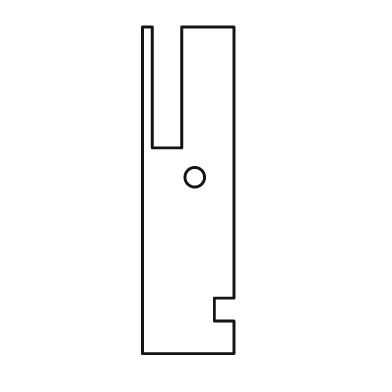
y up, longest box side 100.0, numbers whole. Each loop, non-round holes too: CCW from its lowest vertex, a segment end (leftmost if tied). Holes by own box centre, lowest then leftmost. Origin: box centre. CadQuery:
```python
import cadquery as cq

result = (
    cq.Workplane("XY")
    .moveTo(-14.0, -50.0)
    .lineTo(14.0, -50.0)
    .lineTo(14.0, -40.0)
    .lineTo(8.0, -40.0)
    .lineTo(8.0, -33.0)
    .lineTo(14.0, -33.0)
    .lineTo(14.0, 50.0)
    .lineTo(-2.0, 50.0)
    .lineTo(-2.0, 13.0)
    .lineTo(-11.0, 13.0)
    .lineTo(-11.0, 50.0)
    .lineTo(-14.0, 50.0)
    .close()
    .moveTo(2.0, 4.0)
    .circle(3.0)
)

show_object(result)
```